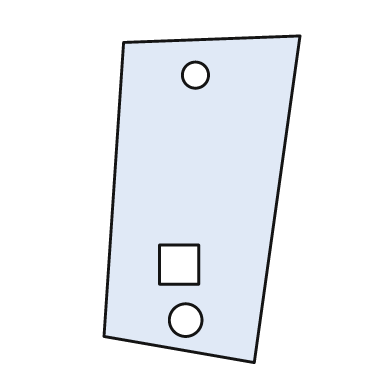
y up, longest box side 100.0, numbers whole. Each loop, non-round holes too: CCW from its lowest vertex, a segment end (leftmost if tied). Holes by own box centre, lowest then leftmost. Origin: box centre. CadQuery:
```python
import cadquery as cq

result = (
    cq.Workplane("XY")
    .moveTo(16.0, -50.0)
    .lineTo(30.0, 50.0)
    .lineTo(-24.0, 48.0)
    .lineTo(-30.0, -42.0)
    .close()
    .moveTo(-5.0, -37.0)
    .circle(5.0)
    .moveTo(-13.0, -26.0)
    .lineTo(-1.0, -26.0)
    .lineTo(-1.0, -14.0)
    .lineTo(-13.0, -14.0)
    .close()
    .moveTo(-2.0, 38.0)
    .circle(4.0)
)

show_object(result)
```